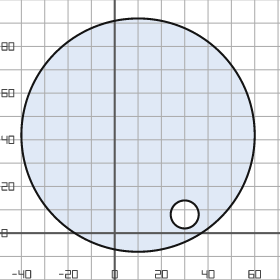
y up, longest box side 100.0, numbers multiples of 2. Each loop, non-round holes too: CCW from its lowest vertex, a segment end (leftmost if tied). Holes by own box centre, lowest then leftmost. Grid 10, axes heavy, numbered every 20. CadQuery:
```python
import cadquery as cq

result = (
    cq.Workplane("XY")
    .moveTo(10.0, 42.0)
    .circle(50.0)
    .moveTo(30.0, 8.0)
    .circle(6.0)
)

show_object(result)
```